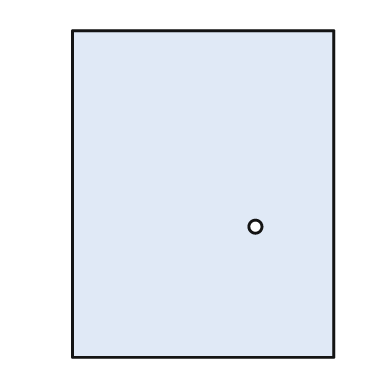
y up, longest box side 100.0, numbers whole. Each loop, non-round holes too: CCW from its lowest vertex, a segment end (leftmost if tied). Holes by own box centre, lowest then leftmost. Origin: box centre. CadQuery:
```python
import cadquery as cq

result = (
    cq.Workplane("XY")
    .moveTo(-40.0, -50.0)
    .lineTo(40.0, -50.0)
    .lineTo(40.0, 50.0)
    .lineTo(-40.0, 50.0)
    .close()
    .moveTo(16.0, -10.0)
    .circle(2.0)
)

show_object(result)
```